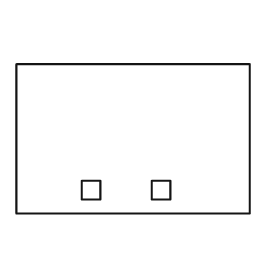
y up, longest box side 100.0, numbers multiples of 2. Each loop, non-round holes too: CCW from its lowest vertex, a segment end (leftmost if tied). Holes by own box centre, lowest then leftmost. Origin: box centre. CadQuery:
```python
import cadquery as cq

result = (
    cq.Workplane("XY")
    .moveTo(-50.0, -32.0)
    .lineTo(50.0, -32.0)
    .lineTo(50.0, 32.0)
    .lineTo(-50.0, 32.0)
    .close()
    .moveTo(-22.0, -26.0)
    .lineTo(-14.0, -26.0)
    .lineTo(-14.0, -18.0)
    .lineTo(-22.0, -18.0)
    .close()
    .moveTo(8.0, -26.0)
    .lineTo(16.0, -26.0)
    .lineTo(16.0, -18.0)
    .lineTo(8.0, -18.0)
    .close()
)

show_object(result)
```